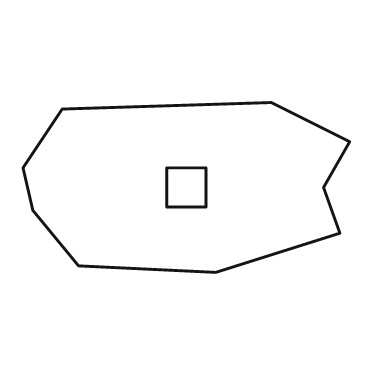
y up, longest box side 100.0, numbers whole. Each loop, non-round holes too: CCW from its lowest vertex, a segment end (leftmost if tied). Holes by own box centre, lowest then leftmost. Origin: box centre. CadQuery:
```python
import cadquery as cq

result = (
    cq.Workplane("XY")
    .moveTo(9.0, -26.0)
    .lineTo(47.0, -14.0)
    .lineTo(42.0, 0.0)
    .lineTo(50.0, 14.0)
    .lineTo(26.0, 26.0)
    .lineTo(-38.0, 24.0)
    .lineTo(-50.0, 6.0)
    .lineTo(-47.0, -7.0)
    .lineTo(-33.0, -24.0)
    .close()
    .moveTo(-6.0, -6.0)
    .lineTo(6.0, -6.0)
    .lineTo(6.0, 6.0)
    .lineTo(-6.0, 6.0)
    .close()
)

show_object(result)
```